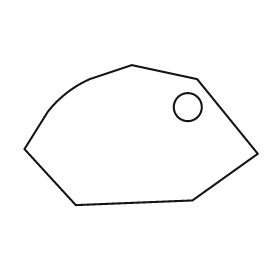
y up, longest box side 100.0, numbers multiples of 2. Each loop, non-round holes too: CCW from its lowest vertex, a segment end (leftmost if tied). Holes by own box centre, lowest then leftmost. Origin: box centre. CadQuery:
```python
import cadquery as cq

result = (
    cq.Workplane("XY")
    .moveTo(-28.0, -30.0)
    .lineTo(22.0, -28.0)
    .lineTo(50.0, -8.0)
    .lineTo(24.0, 24.0)
    .lineTo(-4.0, 30.0)
    .lineTo(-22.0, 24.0)
    .threePointArc((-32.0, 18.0), (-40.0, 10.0))
    .lineTo(-50.0, -6.0)
    .close()
    .moveTo(20.0, 12.0)
    .circle(6.0)
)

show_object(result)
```